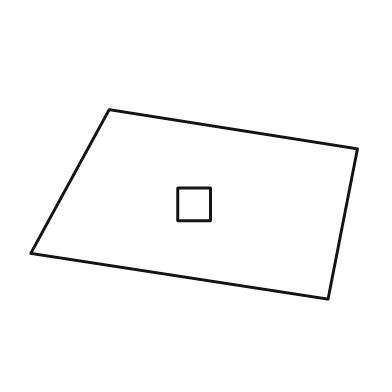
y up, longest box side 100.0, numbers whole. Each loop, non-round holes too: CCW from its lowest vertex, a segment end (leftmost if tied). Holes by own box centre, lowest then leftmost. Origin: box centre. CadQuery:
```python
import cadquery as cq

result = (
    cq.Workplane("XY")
    .moveTo(41.0, -29.0)
    .lineTo(50.0, 17.0)
    .lineTo(-26.0, 29.0)
    .lineTo(-50.0, -15.0)
    .close()
    .moveTo(-5.0, -5.0)
    .lineTo(5.0, -5.0)
    .lineTo(5.0, 5.0)
    .lineTo(-5.0, 5.0)
    .close()
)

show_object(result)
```